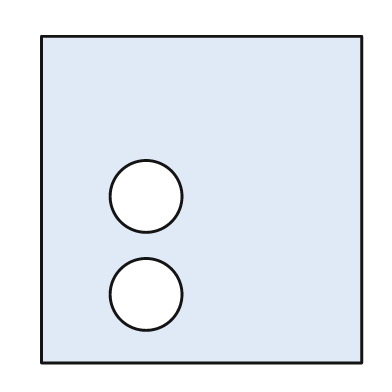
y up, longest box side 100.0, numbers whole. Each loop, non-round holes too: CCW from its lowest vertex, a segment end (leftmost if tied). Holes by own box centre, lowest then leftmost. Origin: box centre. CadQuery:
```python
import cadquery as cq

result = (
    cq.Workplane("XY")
    .moveTo(-49.0, -50.0)
    .lineTo(49.0, -50.0)
    .lineTo(49.0, 50.0)
    .lineTo(-49.0, 50.0)
    .close()
    .moveTo(-17.0, -29.0)
    .circle(11.0)
    .moveTo(-17.0, 1.0)
    .circle(11.0)
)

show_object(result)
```